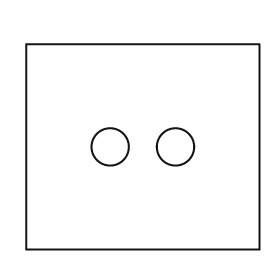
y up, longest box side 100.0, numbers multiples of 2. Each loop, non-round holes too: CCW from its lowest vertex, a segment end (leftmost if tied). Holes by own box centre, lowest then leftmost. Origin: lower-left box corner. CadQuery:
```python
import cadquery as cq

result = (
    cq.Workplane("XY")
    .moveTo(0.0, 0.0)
    .lineTo(100.0, 0.0)
    .lineTo(100.0, 88.0)
    .lineTo(0.0, 88.0)
    .close()
    .moveTo(36.0, 44.0)
    .circle(8.0)
    .moveTo(64.0, 44.0)
    .circle(8.0)
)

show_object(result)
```